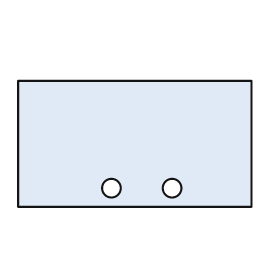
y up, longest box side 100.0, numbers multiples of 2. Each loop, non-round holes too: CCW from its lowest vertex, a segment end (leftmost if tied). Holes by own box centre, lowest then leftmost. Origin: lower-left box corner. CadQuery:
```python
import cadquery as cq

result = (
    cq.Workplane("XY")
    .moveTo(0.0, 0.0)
    .lineTo(100.0, 0.0)
    .lineTo(100.0, 54.0)
    .lineTo(0.0, 54.0)
    .close()
    .moveTo(40.0, 8.0)
    .circle(4.0)
    .moveTo(66.0, 8.0)
    .circle(4.0)
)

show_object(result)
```